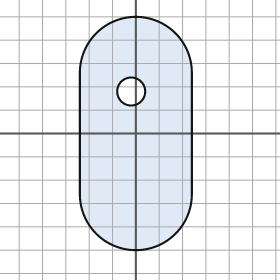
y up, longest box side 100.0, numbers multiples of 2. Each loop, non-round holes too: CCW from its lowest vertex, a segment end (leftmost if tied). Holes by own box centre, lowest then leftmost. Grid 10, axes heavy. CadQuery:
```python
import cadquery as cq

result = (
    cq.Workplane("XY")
    .moveTo(-24.0, -26.0)
    .threePointArc((0.0, -50.0), (24.0, -26.0))
    .lineTo(24.0, 26.0)
    .threePointArc((0.0, 50.0), (-24.0, 26.0))
    .close()
    .moveTo(-2.0, 18.0)
    .circle(6.0)
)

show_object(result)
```